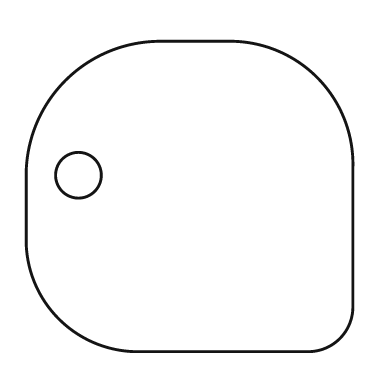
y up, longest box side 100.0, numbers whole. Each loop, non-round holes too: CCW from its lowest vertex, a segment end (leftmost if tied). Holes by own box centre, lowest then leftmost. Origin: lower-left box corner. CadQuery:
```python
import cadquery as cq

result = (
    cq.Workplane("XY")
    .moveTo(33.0, 0.0)
    .lineTo(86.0, 0.0)
    .threePointArc((96.0, 4.0), (100.0, 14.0))
    .lineTo(100.0, 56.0)
    .threePointArc((89.0, 84.0), (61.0, 95.0))
    .lineTo(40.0, 95.0)
    .threePointArc((12.0, 83.0), (0.0, 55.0))
    .lineTo(0.0, 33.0)
    .threePointArc((10.0, 10.0), (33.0, 0.0))
    .close()
    .moveTo(16.0, 54.0)
    .circle(7.0)
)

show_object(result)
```